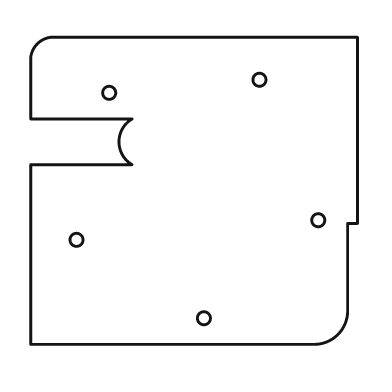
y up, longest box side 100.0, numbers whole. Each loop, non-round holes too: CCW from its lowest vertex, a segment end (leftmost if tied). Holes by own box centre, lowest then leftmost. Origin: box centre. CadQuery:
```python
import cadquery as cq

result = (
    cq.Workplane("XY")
    .moveTo(-50.0, -47.0)
    .lineTo(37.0, -47.0)
    .threePointArc((44.0, -44.0), (47.0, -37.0))
    .lineTo(47.0, -10.0)
    .lineTo(50.0, -10.0)
    .lineTo(50.0, 47.0)
    .lineTo(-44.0, 47.0)
    .threePointArc((-48.0, 45.0), (-50.0, 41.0))
    .lineTo(-50.0, 22.0)
    .lineTo(-19.0, 22.0)
    .threePointArc((-23.0, 15.0), (-19.0, 8.0))
    .lineTo(-50.0, 8.0)
    .close()
    .moveTo(3.0, -39.0)
    .circle(2.0)
    .moveTo(-36.0, -15.0)
    .circle(2.0)
    .moveTo(38.0, -9.0)
    .circle(2.0)
    .moveTo(-26.0, 30.0)
    .circle(2.0)
    .moveTo(20.0, 34.0)
    .circle(2.0)
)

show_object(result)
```